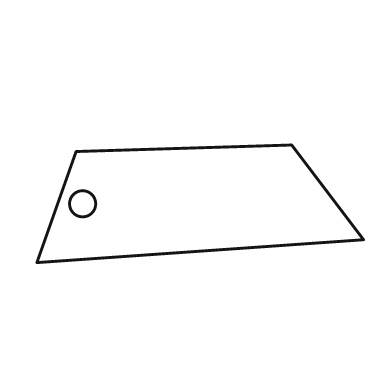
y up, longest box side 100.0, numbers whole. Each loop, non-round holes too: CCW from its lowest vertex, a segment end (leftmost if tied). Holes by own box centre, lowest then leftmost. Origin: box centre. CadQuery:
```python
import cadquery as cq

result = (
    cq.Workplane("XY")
    .moveTo(-50.0, -18.0)
    .lineTo(50.0, -11.0)
    .lineTo(28.0, 18.0)
    .lineTo(-38.0, 16.0)
    .close()
    .moveTo(-36.0, 0.0)
    .circle(4.0)
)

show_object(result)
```